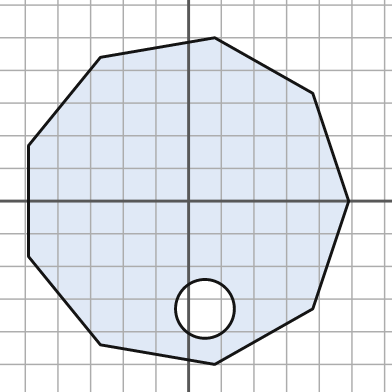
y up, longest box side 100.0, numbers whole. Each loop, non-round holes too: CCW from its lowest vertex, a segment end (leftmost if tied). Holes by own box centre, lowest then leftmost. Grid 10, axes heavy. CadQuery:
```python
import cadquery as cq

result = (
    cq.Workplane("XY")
    .moveTo(8.0, -50.0)
    .lineTo(38.0, -33.0)
    .lineTo(49.0, 0.0)
    .lineTo(38.0, 33.0)
    .lineTo(8.0, 50.0)
    .lineTo(-27.0, 44.0)
    .lineTo(-49.0, 17.0)
    .lineTo(-49.0, -17.0)
    .lineTo(-27.0, -44.0)
    .close()
    .moveTo(5.0, -33.0)
    .circle(9.0)
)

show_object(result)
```